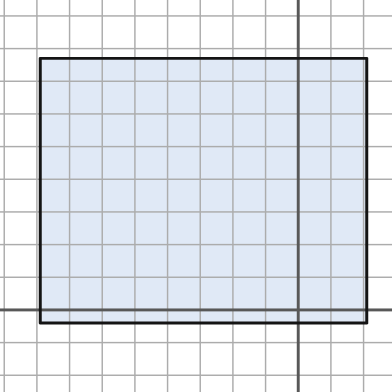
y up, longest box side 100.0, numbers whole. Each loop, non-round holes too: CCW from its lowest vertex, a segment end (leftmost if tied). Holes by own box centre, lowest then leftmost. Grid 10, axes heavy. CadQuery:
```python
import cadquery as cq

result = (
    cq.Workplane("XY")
    .moveTo(-79.0, -4.0)
    .lineTo(21.0, -4.0)
    .lineTo(21.0, 77.0)
    .lineTo(-79.0, 77.0)
    .close()
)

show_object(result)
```